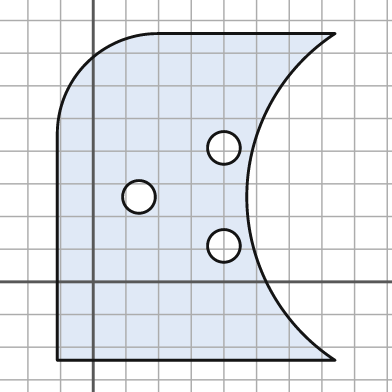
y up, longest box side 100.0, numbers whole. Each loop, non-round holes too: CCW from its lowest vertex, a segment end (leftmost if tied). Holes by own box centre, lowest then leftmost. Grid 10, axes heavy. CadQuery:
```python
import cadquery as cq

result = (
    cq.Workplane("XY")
    .moveTo(-11.0, -24.0)
    .lineTo(74.0, -24.0)
    .threePointArc((47.0, 26.0), (74.0, 76.0))
    .lineTo(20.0, 76.0)
    .threePointArc((-2.0, 67.0), (-11.0, 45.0))
    .close()
    .moveTo(40.0, 11.0)
    .circle(5.0)
    .moveTo(14.0, 26.0)
    .circle(5.0)
    .moveTo(40.0, 41.0)
    .circle(5.0)
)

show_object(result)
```